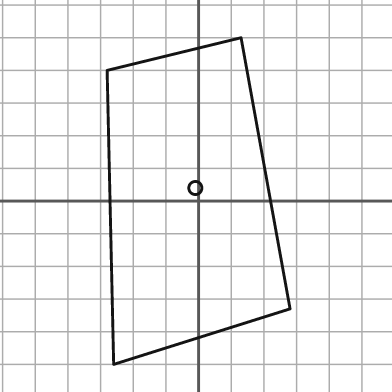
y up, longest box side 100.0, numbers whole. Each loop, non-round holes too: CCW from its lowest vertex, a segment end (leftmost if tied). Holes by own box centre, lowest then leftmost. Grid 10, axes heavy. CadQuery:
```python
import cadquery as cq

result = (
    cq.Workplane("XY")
    .moveTo(-26.0, -50.0)
    .lineTo(28.0, -33.0)
    .lineTo(13.0, 50.0)
    .lineTo(-28.0, 40.0)
    .close()
    .moveTo(-1.0, 4.0)
    .circle(2.0)
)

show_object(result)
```